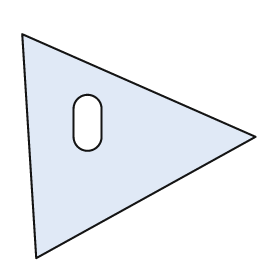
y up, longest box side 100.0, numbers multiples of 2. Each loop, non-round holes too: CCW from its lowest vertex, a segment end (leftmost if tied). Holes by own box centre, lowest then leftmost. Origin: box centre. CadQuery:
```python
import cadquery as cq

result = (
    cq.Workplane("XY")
    .moveTo(-44.0, -48.0)
    .lineTo(50.0, 4.0)
    .lineTo(-50.0, 48.0)
    .close()
    .moveTo(-28.0, 4.0)
    .threePointArc((-22.0, -2.0), (-16.0, 4.0))
    .lineTo(-16.0, 16.0)
    .threePointArc((-22.0, 22.0), (-28.0, 16.0))
    .close()
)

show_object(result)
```